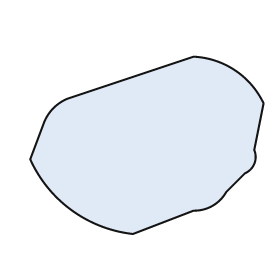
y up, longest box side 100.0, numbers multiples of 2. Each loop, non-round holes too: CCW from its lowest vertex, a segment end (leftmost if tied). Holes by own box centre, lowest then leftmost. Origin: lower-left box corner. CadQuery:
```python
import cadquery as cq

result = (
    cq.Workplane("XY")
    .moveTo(44.0, 0.0)
    .lineTo(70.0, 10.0)
    .threePointArc((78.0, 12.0), (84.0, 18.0))
    .lineTo(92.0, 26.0)
    .threePointArc((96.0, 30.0), (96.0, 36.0))
    .lineTo(100.0, 56.0)
    .threePointArc((88.0, 70.0), (70.0, 76.0))
    .lineTo(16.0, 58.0)
    .threePointArc((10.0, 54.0), (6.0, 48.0))
    .lineTo(0.0, 32.0)
    .threePointArc((18.0, 10.0), (44.0, 0.0))
    .close()
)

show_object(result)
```